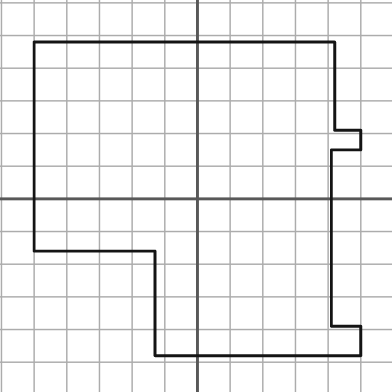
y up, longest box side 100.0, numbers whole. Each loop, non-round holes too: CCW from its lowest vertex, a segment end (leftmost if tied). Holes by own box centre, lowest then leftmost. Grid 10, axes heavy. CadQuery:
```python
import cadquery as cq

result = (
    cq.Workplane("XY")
    .moveTo(-13.0, -48.0)
    .lineTo(50.0, -48.0)
    .lineTo(50.0, -39.0)
    .lineTo(41.0, -39.0)
    .lineTo(41.0, 15.0)
    .lineTo(50.0, 15.0)
    .lineTo(50.0, 21.0)
    .lineTo(42.0, 21.0)
    .lineTo(42.0, 48.0)
    .lineTo(-50.0, 48.0)
    .lineTo(-50.0, -16.0)
    .lineTo(-13.0, -16.0)
    .close()
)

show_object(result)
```